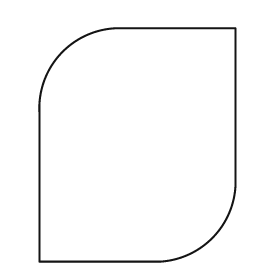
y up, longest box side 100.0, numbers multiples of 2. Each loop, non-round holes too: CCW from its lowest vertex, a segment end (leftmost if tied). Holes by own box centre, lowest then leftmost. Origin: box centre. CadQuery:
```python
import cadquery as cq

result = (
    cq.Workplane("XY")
    .moveTo(-42.0, -50.0)
    .lineTo(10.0, -50.0)
    .threePointArc((32.0, -40.0), (42.0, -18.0))
    .lineTo(42.0, 50.0)
    .lineTo(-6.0, 50.0)
    .threePointArc((-32.0, 40.0), (-42.0, 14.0))
    .close()
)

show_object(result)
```